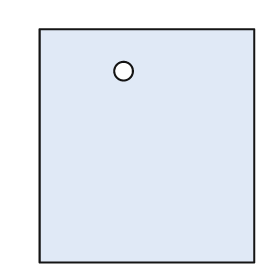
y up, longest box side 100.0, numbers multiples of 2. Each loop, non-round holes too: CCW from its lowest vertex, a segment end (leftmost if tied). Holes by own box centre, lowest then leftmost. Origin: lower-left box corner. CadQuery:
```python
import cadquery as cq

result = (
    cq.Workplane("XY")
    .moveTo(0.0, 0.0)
    .lineTo(92.0, 0.0)
    .lineTo(92.0, 100.0)
    .lineTo(0.0, 100.0)
    .close()
    .moveTo(36.0, 82.0)
    .circle(4.0)
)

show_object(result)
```